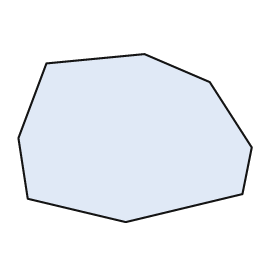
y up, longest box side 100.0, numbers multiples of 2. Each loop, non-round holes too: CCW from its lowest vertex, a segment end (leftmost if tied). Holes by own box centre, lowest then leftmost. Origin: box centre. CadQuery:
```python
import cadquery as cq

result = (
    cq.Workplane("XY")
    .moveTo(-4.0, -36.0)
    .lineTo(46.0, -24.0)
    .lineTo(50.0, -4.0)
    .lineTo(32.0, 24.0)
    .lineTo(4.0, 36.0)
    .lineTo(-38.0, 32.0)
    .lineTo(-50.0, 0.0)
    .lineTo(-46.0, -26.0)
    .close()
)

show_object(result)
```